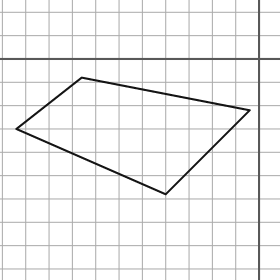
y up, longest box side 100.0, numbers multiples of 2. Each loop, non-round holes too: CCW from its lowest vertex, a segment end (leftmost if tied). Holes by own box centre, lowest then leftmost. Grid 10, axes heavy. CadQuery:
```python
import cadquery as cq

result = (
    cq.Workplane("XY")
    .moveTo(-40.0, -58.0)
    .lineTo(-4.0, -22.0)
    .lineTo(-76.0, -8.0)
    .lineTo(-104.0, -30.0)
    .close()
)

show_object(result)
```